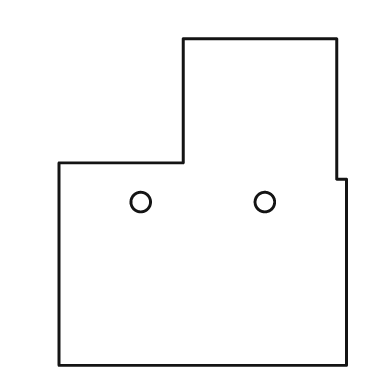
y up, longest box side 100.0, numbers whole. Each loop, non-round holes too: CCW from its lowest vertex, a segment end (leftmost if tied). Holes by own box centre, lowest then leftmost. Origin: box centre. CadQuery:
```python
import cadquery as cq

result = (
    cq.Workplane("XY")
    .moveTo(-44.0, -50.0)
    .lineTo(44.0, -50.0)
    .lineTo(44.0, 7.0)
    .lineTo(41.0, 7.0)
    .lineTo(41.0, 50.0)
    .lineTo(-6.0, 50.0)
    .lineTo(-6.0, 12.0)
    .lineTo(-44.0, 12.0)
    .close()
    .moveTo(-19.0, 0.0)
    .circle(3.0)
    .moveTo(19.0, 0.0)
    .circle(3.0)
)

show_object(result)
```